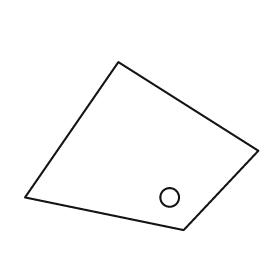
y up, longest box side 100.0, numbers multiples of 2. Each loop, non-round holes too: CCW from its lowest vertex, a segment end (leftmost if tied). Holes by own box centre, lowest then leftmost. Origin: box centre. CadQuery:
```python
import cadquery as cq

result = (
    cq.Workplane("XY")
    .moveTo(18.0, -36.0)
    .lineTo(50.0, -2.0)
    .lineTo(-10.0, 36.0)
    .lineTo(-50.0, -22.0)
    .close()
    .moveTo(12.0, -22.0)
    .circle(4.0)
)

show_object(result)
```